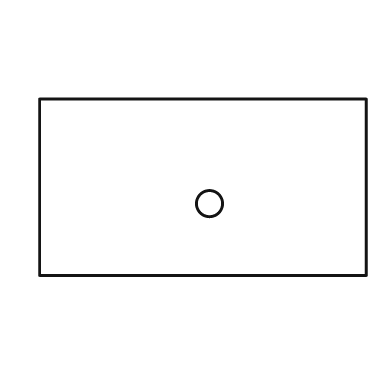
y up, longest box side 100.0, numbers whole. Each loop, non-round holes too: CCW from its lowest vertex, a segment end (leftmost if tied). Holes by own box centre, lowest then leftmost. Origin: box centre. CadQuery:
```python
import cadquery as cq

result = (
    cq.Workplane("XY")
    .moveTo(-50.0, -27.0)
    .lineTo(50.0, -27.0)
    .lineTo(50.0, 27.0)
    .lineTo(-50.0, 27.0)
    .close()
    .moveTo(2.0, -5.0)
    .circle(4.0)
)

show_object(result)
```